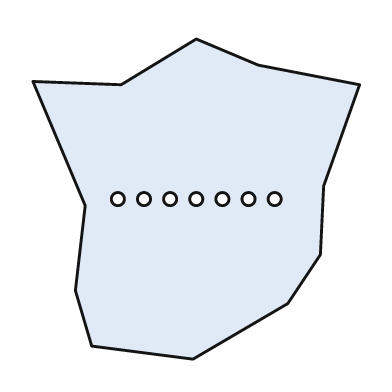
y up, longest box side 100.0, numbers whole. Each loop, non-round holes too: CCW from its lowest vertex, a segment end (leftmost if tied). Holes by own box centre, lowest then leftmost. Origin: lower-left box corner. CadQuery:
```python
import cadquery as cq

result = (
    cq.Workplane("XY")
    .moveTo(49.0, 0.0)
    .lineTo(78.0, 17.0)
    .lineTo(88.0, 32.0)
    .lineTo(89.0, 53.0)
    .lineTo(100.0, 84.0)
    .lineTo(69.0, 90.0)
    .lineTo(50.0, 98.0)
    .lineTo(27.0, 84.0)
    .lineTo(0.0, 85.0)
    .lineTo(16.0, 47.0)
    .lineTo(13.0, 21.0)
    .lineTo(18.0, 4.0)
    .close()
    .moveTo(26.0, 49.0)
    .circle(2.0)
    .moveTo(34.0, 49.0)
    .circle(2.0)
    .moveTo(42.0, 49.0)
    .circle(2.0)
    .moveTo(50.0, 49.0)
    .circle(2.0)
    .moveTo(58.0, 49.0)
    .circle(2.0)
    .moveTo(66.0, 49.0)
    .circle(2.0)
    .moveTo(74.0, 49.0)
    .circle(2.0)
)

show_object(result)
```